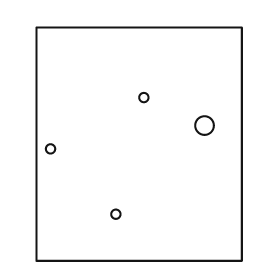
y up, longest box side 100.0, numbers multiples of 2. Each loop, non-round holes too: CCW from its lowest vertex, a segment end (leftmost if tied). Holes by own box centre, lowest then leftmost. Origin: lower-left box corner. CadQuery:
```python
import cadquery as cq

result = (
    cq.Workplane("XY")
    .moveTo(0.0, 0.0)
    .lineTo(88.0, 0.0)
    .lineTo(88.0, 100.0)
    .lineTo(0.0, 100.0)
    .close()
    .moveTo(34.0, 20.0)
    .circle(2.0)
    .moveTo(6.0, 48.0)
    .circle(2.0)
    .moveTo(72.0, 58.0)
    .circle(4.0)
    .moveTo(46.0, 70.0)
    .circle(2.0)
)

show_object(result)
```